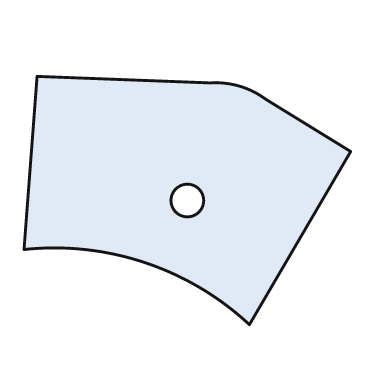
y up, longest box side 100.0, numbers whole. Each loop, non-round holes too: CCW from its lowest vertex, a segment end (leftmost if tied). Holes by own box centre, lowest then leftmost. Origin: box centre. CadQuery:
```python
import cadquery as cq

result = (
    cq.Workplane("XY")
    .moveTo(19.0, -38.0)
    .lineTo(50.0, 15.0)
    .lineTo(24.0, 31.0)
    .threePointArc((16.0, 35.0), (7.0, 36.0))
    .lineTo(-46.0, 38.0)
    .lineTo(-50.0, -15.0)
    .threePointArc((-13.0, -19.0), (19.0, -38.0))
    .close()
    .moveTo(0.0, 0.0)
    .circle(5.0)
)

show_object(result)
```